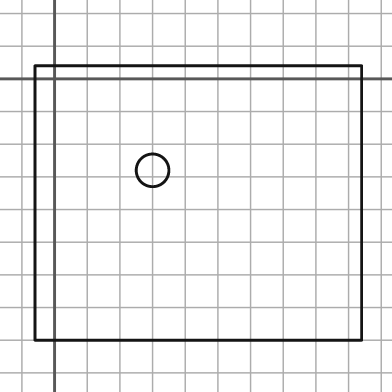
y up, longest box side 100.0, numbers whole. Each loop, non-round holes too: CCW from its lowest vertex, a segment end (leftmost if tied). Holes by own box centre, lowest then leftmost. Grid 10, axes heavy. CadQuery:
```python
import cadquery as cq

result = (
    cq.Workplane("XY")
    .moveTo(-6.0, -80.0)
    .lineTo(94.0, -80.0)
    .lineTo(94.0, 4.0)
    .lineTo(-6.0, 4.0)
    .close()
    .moveTo(30.0, -28.0)
    .circle(5.0)
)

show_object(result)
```